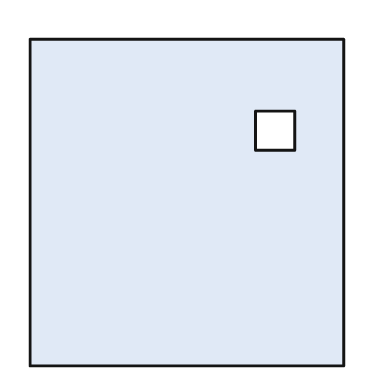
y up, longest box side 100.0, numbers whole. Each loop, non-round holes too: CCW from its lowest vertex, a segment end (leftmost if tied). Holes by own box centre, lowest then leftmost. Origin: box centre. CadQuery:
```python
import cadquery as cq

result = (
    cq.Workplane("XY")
    .moveTo(-48.0, -50.0)
    .lineTo(48.0, -50.0)
    .lineTo(48.0, 50.0)
    .lineTo(-48.0, 50.0)
    .close()
    .moveTo(21.0, 16.0)
    .lineTo(33.0, 16.0)
    .lineTo(33.0, 28.0)
    .lineTo(21.0, 28.0)
    .close()
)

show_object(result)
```